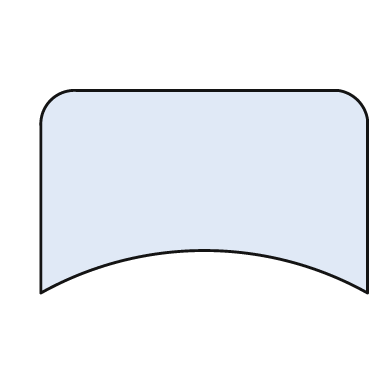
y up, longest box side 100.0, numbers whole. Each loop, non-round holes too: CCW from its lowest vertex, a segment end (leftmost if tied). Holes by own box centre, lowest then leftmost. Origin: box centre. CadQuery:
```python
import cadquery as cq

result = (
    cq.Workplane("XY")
    .moveTo(-50.0, -31.0)
    .threePointArc((0.0, -18.0), (50.0, -31.0))
    .lineTo(50.0, 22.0)
    .threePointArc((47.0, 28.0), (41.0, 31.0))
    .lineTo(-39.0, 31.0)
    .threePointArc((-47.0, 28.0), (-50.0, 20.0))
    .close()
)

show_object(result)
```